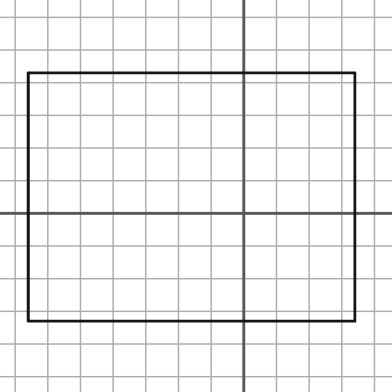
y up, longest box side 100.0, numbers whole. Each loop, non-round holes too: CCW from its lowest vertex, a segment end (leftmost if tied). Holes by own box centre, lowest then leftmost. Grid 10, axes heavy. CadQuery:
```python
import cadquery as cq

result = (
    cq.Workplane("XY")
    .moveTo(-66.0, -33.0)
    .lineTo(34.0, -33.0)
    .lineTo(34.0, 43.0)
    .lineTo(-66.0, 43.0)
    .close()
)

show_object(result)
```